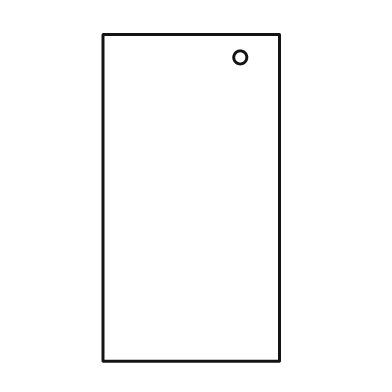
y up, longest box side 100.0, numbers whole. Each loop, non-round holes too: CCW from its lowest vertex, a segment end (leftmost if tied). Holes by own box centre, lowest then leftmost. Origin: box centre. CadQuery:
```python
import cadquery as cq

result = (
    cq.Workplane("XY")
    .moveTo(-27.0, -50.0)
    .lineTo(27.0, -50.0)
    .lineTo(27.0, 50.0)
    .lineTo(-27.0, 50.0)
    .close()
    .moveTo(15.0, 43.0)
    .circle(2.0)
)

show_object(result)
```